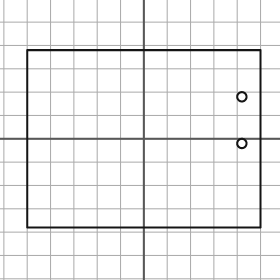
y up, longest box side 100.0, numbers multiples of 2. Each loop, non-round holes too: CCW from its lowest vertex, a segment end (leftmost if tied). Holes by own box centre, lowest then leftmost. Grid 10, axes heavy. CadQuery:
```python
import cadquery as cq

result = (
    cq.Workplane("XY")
    .moveTo(-50.0, -38.0)
    .lineTo(50.0, -38.0)
    .lineTo(50.0, 38.0)
    .lineTo(-50.0, 38.0)
    .close()
    .moveTo(42.0, -2.0)
    .circle(2.0)
    .moveTo(42.0, 18.0)
    .circle(2.0)
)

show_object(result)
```